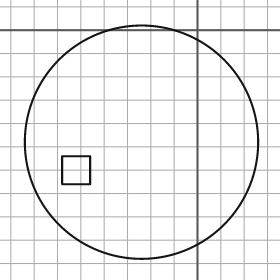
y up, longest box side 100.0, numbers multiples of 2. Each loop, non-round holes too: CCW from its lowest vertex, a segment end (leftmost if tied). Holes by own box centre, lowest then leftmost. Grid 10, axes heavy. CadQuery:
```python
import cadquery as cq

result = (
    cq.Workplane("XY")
    .moveTo(-24.0, -48.0)
    .circle(50.0)
    .moveTo(-58.0, -66.0)
    .lineTo(-46.0, -66.0)
    .lineTo(-46.0, -54.0)
    .lineTo(-58.0, -54.0)
    .close()
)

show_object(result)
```